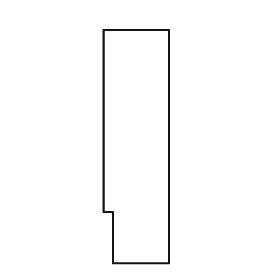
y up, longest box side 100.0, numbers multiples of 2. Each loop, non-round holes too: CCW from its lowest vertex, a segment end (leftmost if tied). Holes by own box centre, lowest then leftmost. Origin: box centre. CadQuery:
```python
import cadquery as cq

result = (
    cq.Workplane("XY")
    .moveTo(-10.0, -50.0)
    .lineTo(14.0, -50.0)
    .lineTo(14.0, 50.0)
    .lineTo(-14.0, 50.0)
    .lineTo(-14.0, -28.0)
    .lineTo(-10.0, -28.0)
    .close()
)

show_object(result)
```